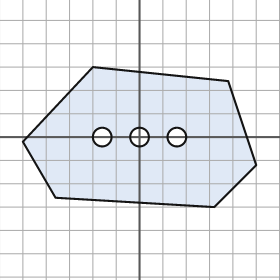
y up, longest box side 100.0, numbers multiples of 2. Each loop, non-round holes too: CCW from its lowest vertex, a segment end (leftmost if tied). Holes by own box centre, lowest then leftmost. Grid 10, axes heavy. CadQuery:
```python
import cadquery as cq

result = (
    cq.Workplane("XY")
    .moveTo(32.0, -30.0)
    .lineTo(50.0, -12.0)
    .lineTo(38.0, 24.0)
    .lineTo(-20.0, 30.0)
    .lineTo(-50.0, -2.0)
    .lineTo(-36.0, -26.0)
    .close()
    .moveTo(-16.0, 0.0)
    .circle(4.0)
    .moveTo(0.0, 0.0)
    .circle(4.0)
    .moveTo(16.0, 0.0)
    .circle(4.0)
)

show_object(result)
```